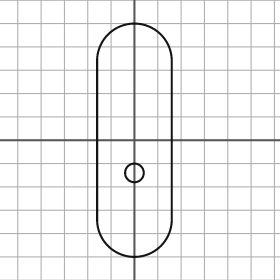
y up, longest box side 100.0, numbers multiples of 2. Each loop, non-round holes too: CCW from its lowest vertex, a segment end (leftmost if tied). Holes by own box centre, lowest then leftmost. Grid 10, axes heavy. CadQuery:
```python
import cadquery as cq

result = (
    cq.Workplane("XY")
    .moveTo(-16.0, -34.0)
    .threePointArc((0.0, -50.0), (16.0, -34.0))
    .lineTo(16.0, 34.0)
    .threePointArc((0.0, 50.0), (-16.0, 34.0))
    .close()
    .moveTo(0.0, -14.0)
    .circle(4.0)
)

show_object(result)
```